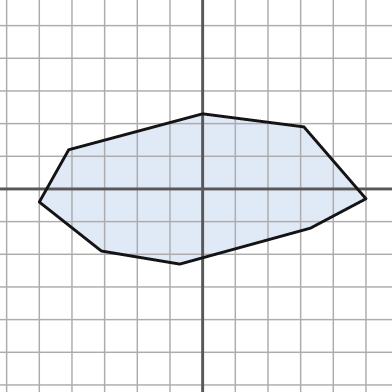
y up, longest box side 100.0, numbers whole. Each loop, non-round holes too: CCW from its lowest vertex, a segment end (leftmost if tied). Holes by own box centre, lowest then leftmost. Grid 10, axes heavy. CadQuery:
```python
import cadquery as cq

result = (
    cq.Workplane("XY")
    .moveTo(-7.0, -23.0)
    .lineTo(33.0, -12.0)
    .lineTo(50.0, -3.0)
    .lineTo(31.0, 19.0)
    .lineTo(0.0, 23.0)
    .lineTo(-41.0, 12.0)
    .lineTo(-50.0, -4.0)
    .lineTo(-31.0, -19.0)
    .close()
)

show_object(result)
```